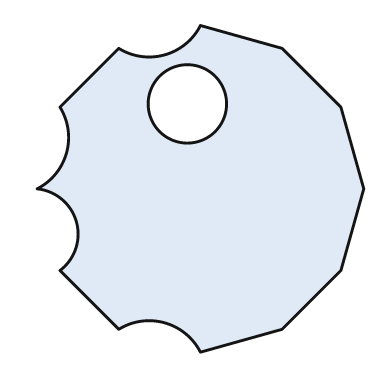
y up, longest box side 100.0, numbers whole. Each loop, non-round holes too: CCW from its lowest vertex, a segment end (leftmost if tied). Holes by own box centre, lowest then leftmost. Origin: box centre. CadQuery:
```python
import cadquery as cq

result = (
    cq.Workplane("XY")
    .moveTo(0.0, -50.0)
    .lineTo(25.0, -43.0)
    .lineTo(43.0, -25.0)
    .lineTo(50.0, 0.0)
    .lineTo(43.0, 25.0)
    .lineTo(25.0, 43.0)
    .lineTo(0.0, 50.0)
    .threePointArc((-11.0, 41.0), (-25.0, 43.0))
    .lineTo(-43.0, 25.0)
    .threePointArc((-41.0, 11.0), (-50.0, 0.0))
    .threePointArc((-38.0, -10.0), (-43.0, -25.0))
    .lineTo(-25.0, -43.0)
    .threePointArc((-11.0, -41.0), (0.0, -50.0))
    .close()
    .moveTo(-4.0, 26.0)
    .circle(12.0)
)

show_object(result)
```